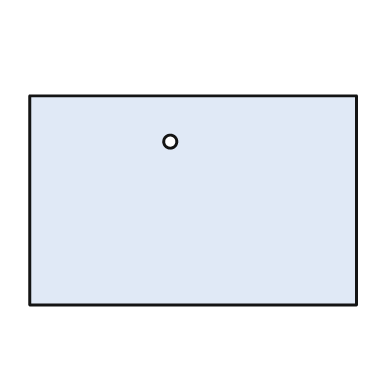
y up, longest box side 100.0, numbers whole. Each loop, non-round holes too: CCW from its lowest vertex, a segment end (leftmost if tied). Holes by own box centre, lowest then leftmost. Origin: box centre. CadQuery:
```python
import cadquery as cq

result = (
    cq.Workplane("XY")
    .moveTo(-50.0, -32.0)
    .lineTo(50.0, -32.0)
    .lineTo(50.0, 32.0)
    .lineTo(-50.0, 32.0)
    .close()
    .moveTo(-7.0, 18.0)
    .circle(2.0)
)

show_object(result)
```